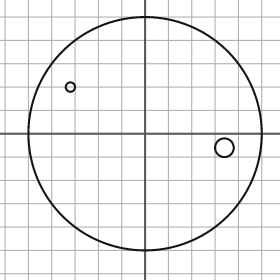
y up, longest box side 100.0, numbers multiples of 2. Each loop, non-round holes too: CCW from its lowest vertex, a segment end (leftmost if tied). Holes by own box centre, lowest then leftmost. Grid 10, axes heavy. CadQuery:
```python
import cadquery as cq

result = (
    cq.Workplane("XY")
    .moveTo(0.0, 0.0)
    .circle(50.0)
    .moveTo(34.0, -6.0)
    .circle(4.0)
    .moveTo(-32.0, 20.0)
    .circle(2.0)
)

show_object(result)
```